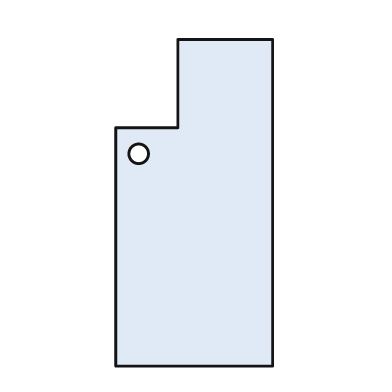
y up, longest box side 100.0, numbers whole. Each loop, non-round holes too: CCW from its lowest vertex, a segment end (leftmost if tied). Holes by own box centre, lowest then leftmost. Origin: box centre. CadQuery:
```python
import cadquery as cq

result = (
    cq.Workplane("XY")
    .moveTo(-24.0, -50.0)
    .lineTo(24.0, -50.0)
    .lineTo(24.0, 50.0)
    .lineTo(-5.0, 50.0)
    .lineTo(-5.0, 23.0)
    .lineTo(-24.0, 23.0)
    .close()
    .moveTo(-17.0, 15.0)
    .circle(3.0)
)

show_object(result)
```